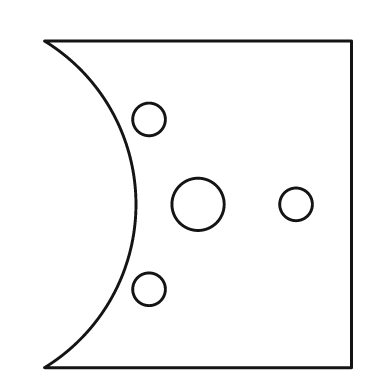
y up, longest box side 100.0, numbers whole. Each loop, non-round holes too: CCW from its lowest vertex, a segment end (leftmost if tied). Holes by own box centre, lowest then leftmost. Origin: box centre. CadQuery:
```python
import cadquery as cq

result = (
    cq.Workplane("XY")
    .moveTo(-47.0, -50.0)
    .lineTo(47.0, -50.0)
    .lineTo(47.0, 50.0)
    .lineTo(-47.0, 50.0)
    .threePointArc((-19.0, 0.0), (-47.0, -50.0))
    .close()
    .moveTo(-15.0, -26.0)
    .circle(5.0)
    .moveTo(0.0, 0.0)
    .circle(8.0)
    .moveTo(30.0, 0.0)
    .circle(5.0)
    .moveTo(-15.0, 26.0)
    .circle(5.0)
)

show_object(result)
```